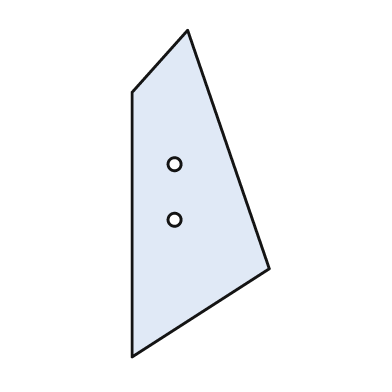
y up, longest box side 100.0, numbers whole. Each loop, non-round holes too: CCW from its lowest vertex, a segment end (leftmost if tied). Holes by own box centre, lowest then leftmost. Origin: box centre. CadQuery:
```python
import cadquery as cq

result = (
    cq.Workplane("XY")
    .moveTo(-21.0, -50.0)
    .lineTo(21.0, -23.0)
    .lineTo(-4.0, 50.0)
    .lineTo(-21.0, 31.0)
    .close()
    .moveTo(-8.0, -8.0)
    .circle(2.0)
    .moveTo(-8.0, 9.0)
    .circle(2.0)
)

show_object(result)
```